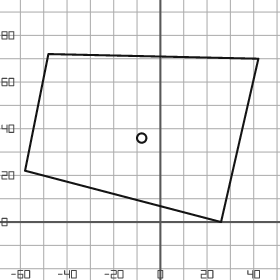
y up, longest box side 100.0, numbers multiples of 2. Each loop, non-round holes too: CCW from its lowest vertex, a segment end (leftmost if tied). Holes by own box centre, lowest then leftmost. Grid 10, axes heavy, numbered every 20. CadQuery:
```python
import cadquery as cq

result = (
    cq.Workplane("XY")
    .moveTo(26.0, 0.0)
    .lineTo(42.0, 70.0)
    .lineTo(-48.0, 72.0)
    .lineTo(-58.0, 22.0)
    .close()
    .moveTo(-8.0, 36.0)
    .circle(2.0)
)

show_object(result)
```